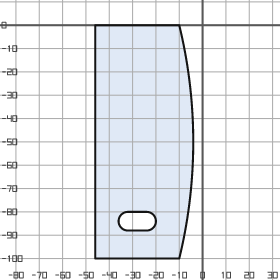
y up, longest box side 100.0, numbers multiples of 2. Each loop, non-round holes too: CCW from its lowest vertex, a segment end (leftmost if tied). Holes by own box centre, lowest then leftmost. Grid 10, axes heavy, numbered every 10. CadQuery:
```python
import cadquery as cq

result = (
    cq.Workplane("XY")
    .moveTo(-46.0, -100.0)
    .lineTo(-10.0, -100.0)
    .threePointArc((-4.0, -50.0), (-10.0, 0.0))
    .lineTo(-46.0, 0.0)
    .close()
    .moveTo(-32.0, -88.0)
    .lineTo(-24.0, -88.0)
    .threePointArc((-20.0, -84.0), (-24.0, -80.0))
    .lineTo(-32.0, -80.0)
    .threePointArc((-36.0, -84.0), (-32.0, -88.0))
    .close()
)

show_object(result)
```